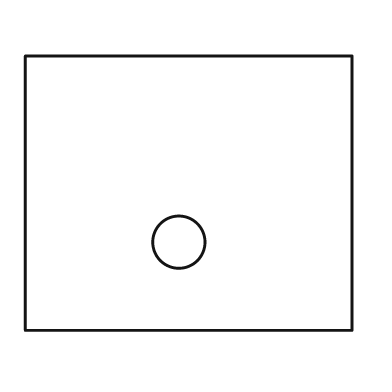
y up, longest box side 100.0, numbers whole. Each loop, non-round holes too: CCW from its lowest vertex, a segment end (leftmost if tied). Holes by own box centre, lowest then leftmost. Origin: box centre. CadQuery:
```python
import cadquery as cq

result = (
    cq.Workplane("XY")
    .moveTo(-50.0, -42.0)
    .lineTo(50.0, -42.0)
    .lineTo(50.0, 42.0)
    .lineTo(-50.0, 42.0)
    .close()
    .moveTo(-3.0, -15.0)
    .circle(8.0)
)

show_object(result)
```